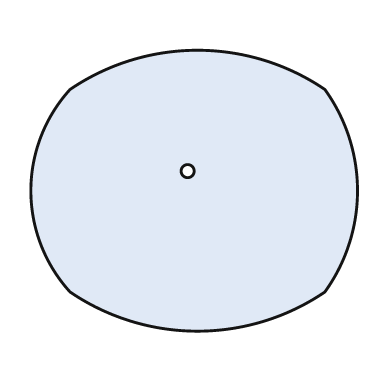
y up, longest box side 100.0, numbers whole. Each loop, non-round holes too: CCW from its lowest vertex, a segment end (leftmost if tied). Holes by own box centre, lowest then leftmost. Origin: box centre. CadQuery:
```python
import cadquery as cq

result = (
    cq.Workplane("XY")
    .moveTo(-38.0, -31.0)
    .threePointArc((1.0, -43.0), (40.0, -31.0))
    .threePointArc((50.0, 0.0), (40.0, 31.0))
    .threePointArc((1.0, 43.0), (-38.0, 31.0))
    .threePointArc((-50.0, 0.0), (-38.0, -31.0))
    .close()
    .moveTo(-2.0, 6.0)
    .circle(2.0)
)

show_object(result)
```